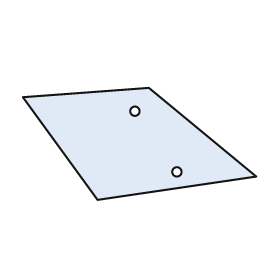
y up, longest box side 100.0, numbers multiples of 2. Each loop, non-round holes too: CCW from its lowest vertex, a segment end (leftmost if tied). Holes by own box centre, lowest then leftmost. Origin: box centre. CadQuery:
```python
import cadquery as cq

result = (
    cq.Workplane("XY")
    .moveTo(-18.0, -24.0)
    .lineTo(50.0, -14.0)
    .lineTo(4.0, 24.0)
    .lineTo(-50.0, 20.0)
    .close()
    .moveTo(16.0, -12.0)
    .circle(2.0)
    .moveTo(-2.0, 14.0)
    .circle(2.0)
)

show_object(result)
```